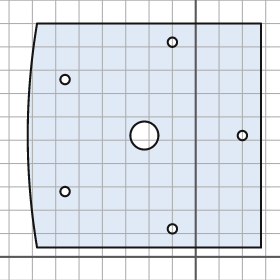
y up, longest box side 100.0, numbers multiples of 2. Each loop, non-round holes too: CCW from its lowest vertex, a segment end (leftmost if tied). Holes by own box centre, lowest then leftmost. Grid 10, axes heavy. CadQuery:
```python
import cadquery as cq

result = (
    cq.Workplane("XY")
    .moveTo(-68.0, 4.0)
    .lineTo(28.0, 4.0)
    .lineTo(28.0, 100.0)
    .lineTo(-68.0, 100.0)
    .threePointArc((-72.0, 52.0), (-68.0, 4.0))
    .close()
    .moveTo(-10.0, 12.0)
    .circle(2.0)
    .moveTo(-56.0, 28.0)
    .circle(2.0)
    .moveTo(-22.0, 52.0)
    .circle(6.0)
    .moveTo(20.0, 52.0)
    .circle(2.0)
    .moveTo(-56.0, 76.0)
    .circle(2.0)
    .moveTo(-10.0, 92.0)
    .circle(2.0)
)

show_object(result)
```